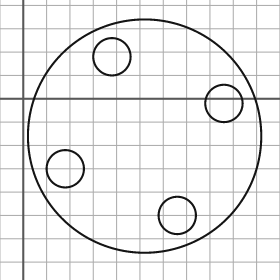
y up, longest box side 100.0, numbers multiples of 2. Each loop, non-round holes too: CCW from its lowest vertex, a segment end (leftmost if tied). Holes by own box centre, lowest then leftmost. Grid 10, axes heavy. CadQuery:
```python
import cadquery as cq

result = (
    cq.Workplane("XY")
    .moveTo(52.0, -16.0)
    .circle(50.0)
    .moveTo(66.0, -50.0)
    .circle(8.0)
    .moveTo(18.0, -30.0)
    .circle(8.0)
    .moveTo(86.0, -2.0)
    .circle(8.0)
    .moveTo(38.0, 18.0)
    .circle(8.0)
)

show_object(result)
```